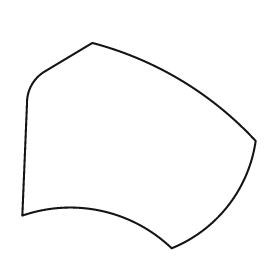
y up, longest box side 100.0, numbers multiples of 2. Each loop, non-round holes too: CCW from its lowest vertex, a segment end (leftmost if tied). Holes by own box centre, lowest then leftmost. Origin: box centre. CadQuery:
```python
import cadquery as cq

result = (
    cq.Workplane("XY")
    .moveTo(14.0, -44.0)
    .threePointArc((38.0, -26.0), (50.0, 2.0))
    .threePointArc((18.0, 28.0), (-20.0, 44.0))
    .lineTo(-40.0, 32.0)
    .threePointArc((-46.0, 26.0), (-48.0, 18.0))
    .lineTo(-50.0, -30.0)
    .threePointArc((-16.0, -28.0), (14.0, -44.0))
    .close()
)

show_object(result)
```